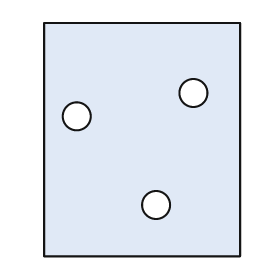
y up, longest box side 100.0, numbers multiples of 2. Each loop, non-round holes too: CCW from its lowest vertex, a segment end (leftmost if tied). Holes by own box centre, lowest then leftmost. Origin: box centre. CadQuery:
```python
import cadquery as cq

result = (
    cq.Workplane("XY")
    .moveTo(-42.0, -50.0)
    .lineTo(42.0, -50.0)
    .lineTo(42.0, 50.0)
    .lineTo(-42.0, 50.0)
    .close()
    .moveTo(6.0, -28.0)
    .circle(6.0)
    .moveTo(-28.0, 10.0)
    .circle(6.0)
    .moveTo(22.0, 20.0)
    .circle(6.0)
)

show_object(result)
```